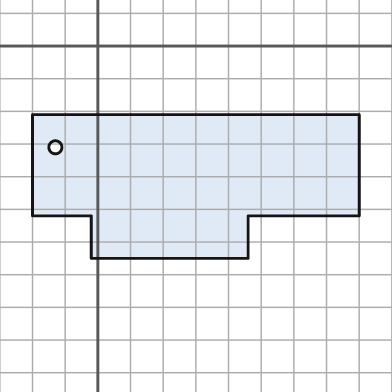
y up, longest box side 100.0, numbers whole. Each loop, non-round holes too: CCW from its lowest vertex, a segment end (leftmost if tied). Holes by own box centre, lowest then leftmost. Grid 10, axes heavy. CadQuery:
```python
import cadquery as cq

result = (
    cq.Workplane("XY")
    .moveTo(-2.0, -65.0)
    .lineTo(46.0, -65.0)
    .lineTo(46.0, -52.0)
    .lineTo(80.0, -52.0)
    .lineTo(80.0, -21.0)
    .lineTo(-20.0, -21.0)
    .lineTo(-20.0, -52.0)
    .lineTo(-2.0, -52.0)
    .close()
    .moveTo(-13.0, -31.0)
    .circle(2.0)
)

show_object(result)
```